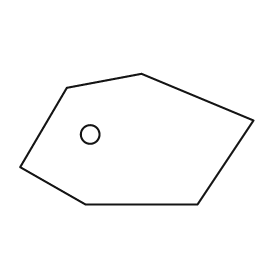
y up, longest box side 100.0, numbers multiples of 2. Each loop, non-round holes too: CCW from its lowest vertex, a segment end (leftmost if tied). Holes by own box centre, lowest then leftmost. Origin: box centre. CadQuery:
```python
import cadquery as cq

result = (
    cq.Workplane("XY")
    .moveTo(-22.0, -28.0)
    .lineTo(26.0, -28.0)
    .lineTo(50.0, 8.0)
    .lineTo(2.0, 28.0)
    .lineTo(-30.0, 22.0)
    .lineTo(-50.0, -12.0)
    .close()
    .moveTo(-20.0, 2.0)
    .circle(4.0)
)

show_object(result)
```